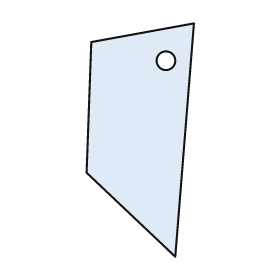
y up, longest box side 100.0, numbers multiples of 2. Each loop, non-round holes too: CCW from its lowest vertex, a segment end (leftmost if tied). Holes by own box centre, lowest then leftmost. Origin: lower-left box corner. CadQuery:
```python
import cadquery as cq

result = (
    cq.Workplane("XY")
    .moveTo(38.0, 0.0)
    .lineTo(46.0, 100.0)
    .lineTo(2.0, 92.0)
    .lineTo(0.0, 36.0)
    .close()
    .moveTo(34.0, 84.0)
    .circle(4.0)
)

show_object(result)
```